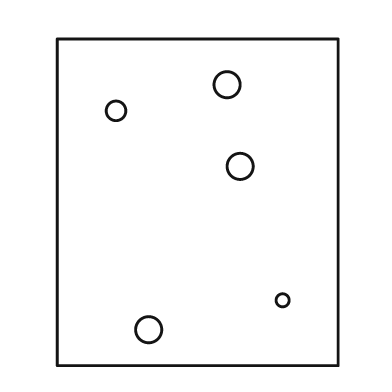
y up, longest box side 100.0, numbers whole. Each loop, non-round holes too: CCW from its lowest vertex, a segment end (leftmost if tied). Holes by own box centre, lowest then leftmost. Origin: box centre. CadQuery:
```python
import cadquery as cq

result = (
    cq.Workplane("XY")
    .moveTo(-43.0, -50.0)
    .lineTo(43.0, -50.0)
    .lineTo(43.0, 50.0)
    .lineTo(-43.0, 50.0)
    .close()
    .moveTo(-15.0, -39.0)
    .circle(4.0)
    .moveTo(26.0, -30.0)
    .circle(2.0)
    .moveTo(13.0, 11.0)
    .circle(4.0)
    .moveTo(-25.0, 28.0)
    .circle(3.0)
    .moveTo(9.0, 36.0)
    .circle(4.0)
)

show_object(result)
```